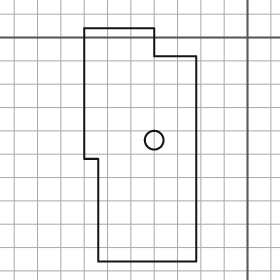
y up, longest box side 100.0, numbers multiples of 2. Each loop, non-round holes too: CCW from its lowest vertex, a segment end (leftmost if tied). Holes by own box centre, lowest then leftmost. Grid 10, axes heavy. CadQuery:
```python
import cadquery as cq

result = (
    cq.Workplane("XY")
    .moveTo(-64.0, -96.0)
    .lineTo(-22.0, -96.0)
    .lineTo(-22.0, -8.0)
    .lineTo(-40.0, -8.0)
    .lineTo(-40.0, 4.0)
    .lineTo(-70.0, 4.0)
    .lineTo(-70.0, -52.0)
    .lineTo(-64.0, -52.0)
    .close()
    .moveTo(-40.0, -44.0)
    .circle(4.0)
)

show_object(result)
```